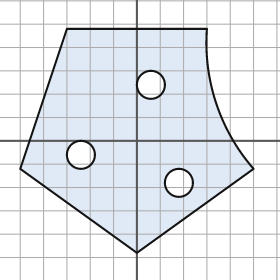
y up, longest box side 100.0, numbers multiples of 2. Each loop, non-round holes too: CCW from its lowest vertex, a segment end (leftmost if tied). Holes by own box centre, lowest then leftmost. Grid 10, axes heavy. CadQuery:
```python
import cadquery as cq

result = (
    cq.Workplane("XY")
    .moveTo(0.0, -48.0)
    .lineTo(50.0, -12.0)
    .threePointArc((34.0, 16.0), (30.0, 48.0))
    .lineTo(-30.0, 48.0)
    .lineTo(-50.0, -12.0)
    .close()
    .moveTo(18.0, -18.0)
    .circle(6.0)
    .moveTo(-24.0, -6.0)
    .circle(6.0)
    .moveTo(6.0, 24.0)
    .circle(6.0)
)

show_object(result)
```